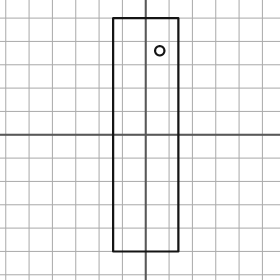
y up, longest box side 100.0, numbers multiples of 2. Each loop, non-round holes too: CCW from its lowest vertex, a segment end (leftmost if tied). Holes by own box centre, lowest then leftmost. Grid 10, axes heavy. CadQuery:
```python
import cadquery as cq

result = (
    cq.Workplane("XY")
    .moveTo(-14.0, -50.0)
    .lineTo(14.0, -50.0)
    .lineTo(14.0, 50.0)
    .lineTo(-14.0, 50.0)
    .close()
    .moveTo(6.0, 36.0)
    .circle(2.0)
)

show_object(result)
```